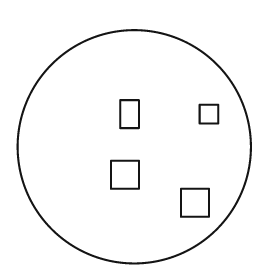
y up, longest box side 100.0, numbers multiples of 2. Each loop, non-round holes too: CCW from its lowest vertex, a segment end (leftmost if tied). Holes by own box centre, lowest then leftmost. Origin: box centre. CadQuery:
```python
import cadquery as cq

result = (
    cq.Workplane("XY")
    .moveTo(0.0, 0.0)
    .circle(50.0)
    .moveTo(20.0, -30.0)
    .lineTo(32.0, -30.0)
    .lineTo(32.0, -18.0)
    .lineTo(20.0, -18.0)
    .close()
    .moveTo(-10.0, -18.0)
    .lineTo(2.0, -18.0)
    .lineTo(2.0, -6.0)
    .lineTo(-10.0, -6.0)
    .close()
    .moveTo(-6.0, 8.0)
    .lineTo(2.0, 8.0)
    .lineTo(2.0, 20.0)
    .lineTo(-6.0, 20.0)
    .close()
    .moveTo(28.0, 10.0)
    .lineTo(36.0, 10.0)
    .lineTo(36.0, 18.0)
    .lineTo(28.0, 18.0)
    .close()
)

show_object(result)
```